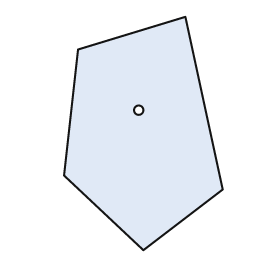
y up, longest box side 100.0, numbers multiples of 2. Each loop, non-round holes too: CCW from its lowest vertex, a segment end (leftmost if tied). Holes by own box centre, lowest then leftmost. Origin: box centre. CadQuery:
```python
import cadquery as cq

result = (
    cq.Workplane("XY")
    .moveTo(0.0, -50.0)
    .lineTo(34.0, -24.0)
    .lineTo(18.0, 50.0)
    .lineTo(-28.0, 36.0)
    .lineTo(-34.0, -18.0)
    .close()
    .moveTo(-2.0, 10.0)
    .circle(2.0)
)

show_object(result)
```